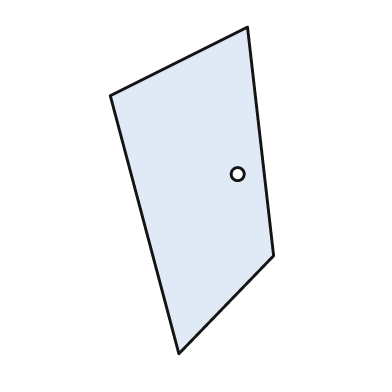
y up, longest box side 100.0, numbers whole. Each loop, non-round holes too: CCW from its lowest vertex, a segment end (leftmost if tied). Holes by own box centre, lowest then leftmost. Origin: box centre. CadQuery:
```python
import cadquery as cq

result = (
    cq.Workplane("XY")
    .moveTo(-4.0, -50.0)
    .lineTo(25.0, -20.0)
    .lineTo(17.0, 50.0)
    .lineTo(-25.0, 29.0)
    .close()
    .moveTo(14.0, 5.0)
    .circle(2.0)
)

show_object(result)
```